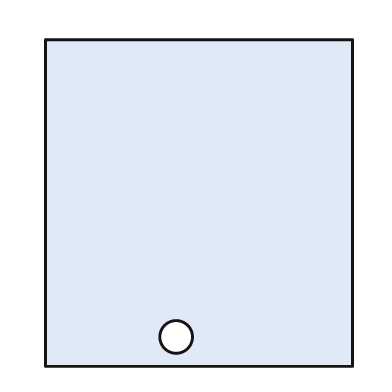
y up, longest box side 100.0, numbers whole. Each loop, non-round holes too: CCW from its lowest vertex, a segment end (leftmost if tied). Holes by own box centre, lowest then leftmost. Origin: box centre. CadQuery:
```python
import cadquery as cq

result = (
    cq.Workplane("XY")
    .moveTo(-47.0, -50.0)
    .lineTo(47.0, -50.0)
    .lineTo(47.0, 50.0)
    .lineTo(-47.0, 50.0)
    .close()
    .moveTo(-7.0, -41.0)
    .circle(5.0)
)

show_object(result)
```